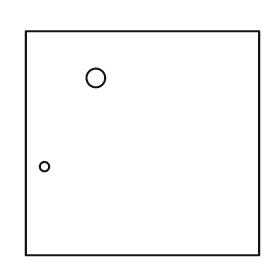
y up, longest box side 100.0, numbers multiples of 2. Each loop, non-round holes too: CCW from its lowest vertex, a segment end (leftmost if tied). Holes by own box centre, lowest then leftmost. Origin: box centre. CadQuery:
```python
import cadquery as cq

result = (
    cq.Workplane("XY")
    .moveTo(-50.0, -48.0)
    .lineTo(50.0, -48.0)
    .lineTo(50.0, 48.0)
    .lineTo(-50.0, 48.0)
    .close()
    .moveTo(-42.0, -10.0)
    .circle(2.0)
    .moveTo(-20.0, 28.0)
    .circle(4.0)
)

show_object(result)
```